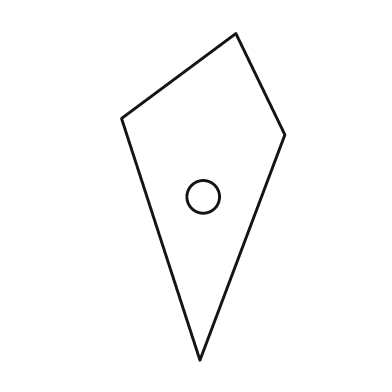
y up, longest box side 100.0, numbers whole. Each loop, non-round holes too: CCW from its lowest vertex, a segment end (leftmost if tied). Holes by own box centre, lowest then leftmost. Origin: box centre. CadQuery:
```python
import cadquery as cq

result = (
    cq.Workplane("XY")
    .moveTo(-1.0, -50.0)
    .lineTo(25.0, 19.0)
    .lineTo(10.0, 50.0)
    .lineTo(-25.0, 24.0)
    .close()
    .moveTo(0.0, 0.0)
    .circle(5.0)
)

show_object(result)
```